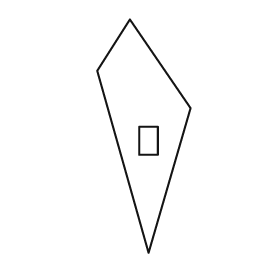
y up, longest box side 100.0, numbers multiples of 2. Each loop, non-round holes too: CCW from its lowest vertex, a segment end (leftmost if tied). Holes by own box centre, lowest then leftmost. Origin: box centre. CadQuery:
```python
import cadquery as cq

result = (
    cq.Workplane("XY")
    .moveTo(2.0, -50.0)
    .lineTo(20.0, 12.0)
    .lineTo(-6.0, 50.0)
    .lineTo(-20.0, 28.0)
    .close()
    .moveTo(-2.0, -8.0)
    .lineTo(6.0, -8.0)
    .lineTo(6.0, 4.0)
    .lineTo(-2.0, 4.0)
    .close()
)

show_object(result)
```